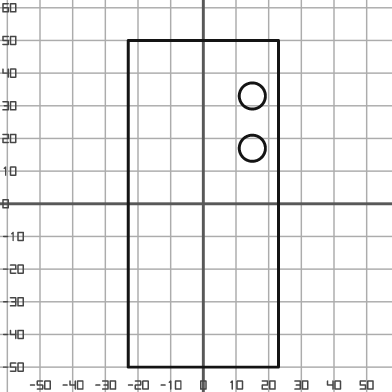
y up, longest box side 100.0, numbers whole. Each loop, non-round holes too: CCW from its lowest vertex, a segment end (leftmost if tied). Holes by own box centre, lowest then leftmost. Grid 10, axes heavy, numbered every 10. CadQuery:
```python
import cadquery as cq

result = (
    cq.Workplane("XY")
    .moveTo(-23.0, -50.0)
    .lineTo(23.0, -50.0)
    .lineTo(23.0, 50.0)
    .lineTo(-23.0, 50.0)
    .close()
    .moveTo(15.0, 17.0)
    .circle(4.0)
    .moveTo(15.0, 33.0)
    .circle(4.0)
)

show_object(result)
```